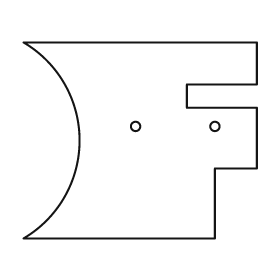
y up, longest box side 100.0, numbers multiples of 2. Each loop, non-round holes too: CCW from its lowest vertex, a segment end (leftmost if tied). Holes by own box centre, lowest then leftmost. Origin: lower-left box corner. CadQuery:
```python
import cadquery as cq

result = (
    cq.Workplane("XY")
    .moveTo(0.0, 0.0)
    .lineTo(82.0, 0.0)
    .lineTo(82.0, 30.0)
    .lineTo(100.0, 30.0)
    .lineTo(100.0, 56.0)
    .lineTo(70.0, 56.0)
    .lineTo(70.0, 66.0)
    .lineTo(100.0, 66.0)
    .lineTo(100.0, 84.0)
    .lineTo(0.0, 84.0)
    .threePointArc((24.0, 42.0), (0.0, 0.0))
    .close()
    .moveTo(48.0, 48.0)
    .circle(2.0)
    .moveTo(82.0, 48.0)
    .circle(2.0)
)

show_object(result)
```